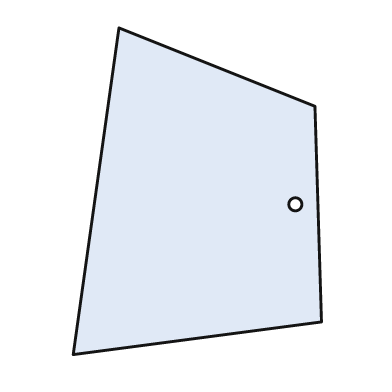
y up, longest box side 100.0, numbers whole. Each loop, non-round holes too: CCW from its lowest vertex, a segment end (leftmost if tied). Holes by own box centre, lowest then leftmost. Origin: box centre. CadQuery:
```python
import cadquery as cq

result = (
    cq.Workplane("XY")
    .moveTo(-38.0, -50.0)
    .lineTo(38.0, -40.0)
    .lineTo(36.0, 26.0)
    .lineTo(-24.0, 50.0)
    .close()
    .moveTo(30.0, -4.0)
    .circle(2.0)
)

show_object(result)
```